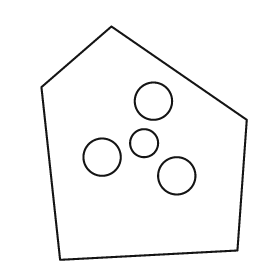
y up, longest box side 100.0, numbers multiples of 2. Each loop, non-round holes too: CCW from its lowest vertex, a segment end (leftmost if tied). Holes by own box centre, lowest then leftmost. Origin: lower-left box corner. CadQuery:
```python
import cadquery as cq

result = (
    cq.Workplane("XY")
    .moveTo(8.0, 0.0)
    .lineTo(84.0, 4.0)
    .lineTo(88.0, 60.0)
    .lineTo(30.0, 100.0)
    .lineTo(0.0, 74.0)
    .close()
    .moveTo(58.0, 36.0)
    .circle(8.0)
    .moveTo(26.0, 44.0)
    .circle(8.0)
    .moveTo(44.0, 50.0)
    .circle(6.0)
    .moveTo(48.0, 68.0)
    .circle(8.0)
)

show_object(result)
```